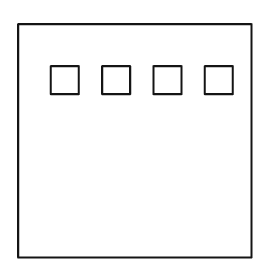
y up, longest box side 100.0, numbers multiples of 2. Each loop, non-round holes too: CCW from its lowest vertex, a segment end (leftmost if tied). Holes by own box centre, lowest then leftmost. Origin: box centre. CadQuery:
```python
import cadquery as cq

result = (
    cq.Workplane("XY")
    .moveTo(-50.0, -50.0)
    .lineTo(50.0, -50.0)
    .lineTo(50.0, 50.0)
    .lineTo(-50.0, 50.0)
    .close()
    .moveTo(-36.0, 20.0)
    .lineTo(-24.0, 20.0)
    .lineTo(-24.0, 32.0)
    .lineTo(-36.0, 32.0)
    .close()
    .moveTo(-14.0, 20.0)
    .lineTo(-2.0, 20.0)
    .lineTo(-2.0, 32.0)
    .lineTo(-14.0, 32.0)
    .close()
    .moveTo(8.0, 20.0)
    .lineTo(20.0, 20.0)
    .lineTo(20.0, 32.0)
    .lineTo(8.0, 32.0)
    .close()
    .moveTo(30.0, 20.0)
    .lineTo(42.0, 20.0)
    .lineTo(42.0, 32.0)
    .lineTo(30.0, 32.0)
    .close()
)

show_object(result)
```